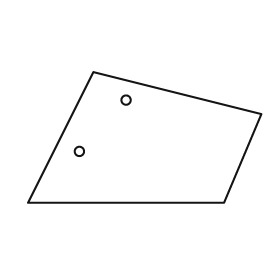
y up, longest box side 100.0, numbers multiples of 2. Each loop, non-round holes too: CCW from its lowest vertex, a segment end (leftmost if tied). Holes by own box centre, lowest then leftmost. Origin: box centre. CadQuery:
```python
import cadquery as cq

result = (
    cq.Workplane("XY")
    .moveTo(-50.0, -28.0)
    .lineTo(34.0, -28.0)
    .lineTo(50.0, 10.0)
    .lineTo(-22.0, 28.0)
    .close()
    .moveTo(-28.0, -6.0)
    .circle(2.0)
    .moveTo(-8.0, 16.0)
    .circle(2.0)
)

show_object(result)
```